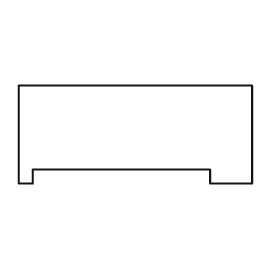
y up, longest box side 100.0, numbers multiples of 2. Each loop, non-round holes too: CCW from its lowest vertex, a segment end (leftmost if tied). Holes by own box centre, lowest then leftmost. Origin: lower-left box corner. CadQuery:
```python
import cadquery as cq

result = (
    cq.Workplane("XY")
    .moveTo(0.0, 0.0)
    .lineTo(6.0, 0.0)
    .lineTo(6.0, 6.0)
    .lineTo(82.0, 6.0)
    .lineTo(82.0, 0.0)
    .lineTo(100.0, 0.0)
    .lineTo(100.0, 42.0)
    .lineTo(0.0, 42.0)
    .close()
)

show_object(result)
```